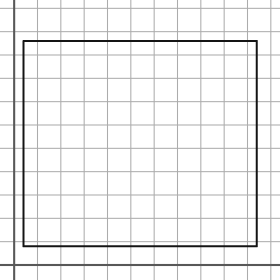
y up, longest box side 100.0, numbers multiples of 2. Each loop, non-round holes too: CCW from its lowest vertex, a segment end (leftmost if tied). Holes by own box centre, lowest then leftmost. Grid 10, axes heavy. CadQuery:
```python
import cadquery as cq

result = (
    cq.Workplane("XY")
    .moveTo(4.0, 8.0)
    .lineTo(104.0, 8.0)
    .lineTo(104.0, 96.0)
    .lineTo(4.0, 96.0)
    .close()
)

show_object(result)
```